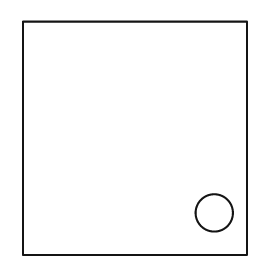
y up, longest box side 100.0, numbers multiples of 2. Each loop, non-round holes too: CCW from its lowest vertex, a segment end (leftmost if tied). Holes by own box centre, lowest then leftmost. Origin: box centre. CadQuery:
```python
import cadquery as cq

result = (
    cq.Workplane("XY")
    .moveTo(-48.0, -50.0)
    .lineTo(48.0, -50.0)
    .lineTo(48.0, 50.0)
    .lineTo(-48.0, 50.0)
    .close()
    .moveTo(34.0, -32.0)
    .circle(8.0)
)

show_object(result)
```